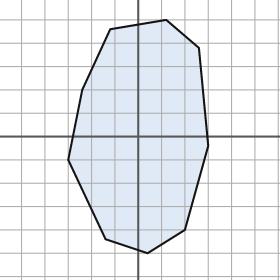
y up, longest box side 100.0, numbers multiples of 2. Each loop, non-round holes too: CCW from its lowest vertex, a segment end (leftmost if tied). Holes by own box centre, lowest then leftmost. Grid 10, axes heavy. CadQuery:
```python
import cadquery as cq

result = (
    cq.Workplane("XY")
    .moveTo(4.0, -50.0)
    .lineTo(20.0, -40.0)
    .lineTo(30.0, -4.0)
    .lineTo(26.0, 38.0)
    .lineTo(12.0, 50.0)
    .lineTo(-12.0, 46.0)
    .lineTo(-24.0, 20.0)
    .lineTo(-30.0, -10.0)
    .lineTo(-14.0, -44.0)
    .close()
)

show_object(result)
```